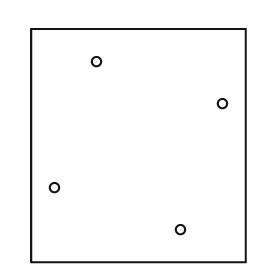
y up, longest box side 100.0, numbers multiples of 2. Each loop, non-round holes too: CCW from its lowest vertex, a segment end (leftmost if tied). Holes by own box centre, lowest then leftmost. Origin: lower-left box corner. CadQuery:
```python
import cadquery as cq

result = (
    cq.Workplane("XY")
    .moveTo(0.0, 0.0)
    .lineTo(92.0, 0.0)
    .lineTo(92.0, 100.0)
    .lineTo(0.0, 100.0)
    .close()
    .moveTo(64.0, 14.0)
    .circle(2.0)
    .moveTo(10.0, 32.0)
    .circle(2.0)
    .moveTo(82.0, 68.0)
    .circle(2.0)
    .moveTo(28.0, 86.0)
    .circle(2.0)
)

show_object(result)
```